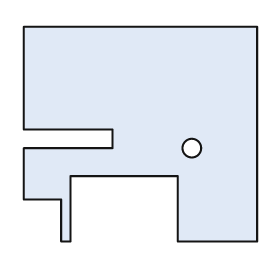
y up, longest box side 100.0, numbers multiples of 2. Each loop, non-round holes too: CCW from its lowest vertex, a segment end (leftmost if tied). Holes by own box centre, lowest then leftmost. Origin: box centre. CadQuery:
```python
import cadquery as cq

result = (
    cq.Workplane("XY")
    .moveTo(-34.0, -46.0)
    .lineTo(-30.0, -46.0)
    .lineTo(-30.0, -18.0)
    .lineTo(16.0, -18.0)
    .lineTo(16.0, -46.0)
    .lineTo(50.0, -46.0)
    .lineTo(50.0, 46.0)
    .lineTo(-50.0, 46.0)
    .lineTo(-50.0, 2.0)
    .lineTo(-12.0, 2.0)
    .lineTo(-12.0, -6.0)
    .lineTo(-50.0, -6.0)
    .lineTo(-50.0, -28.0)
    .lineTo(-34.0, -28.0)
    .close()
    .moveTo(22.0, -6.0)
    .circle(4.0)
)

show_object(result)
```